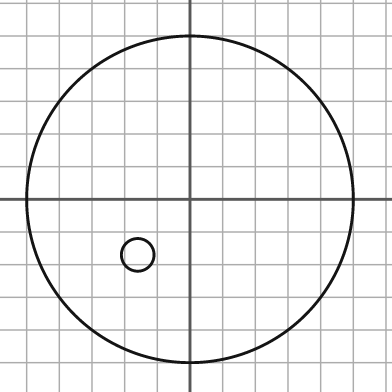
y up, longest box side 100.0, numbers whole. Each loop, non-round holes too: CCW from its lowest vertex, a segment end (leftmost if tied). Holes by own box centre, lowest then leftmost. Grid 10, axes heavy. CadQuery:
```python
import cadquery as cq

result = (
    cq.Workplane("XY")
    .moveTo(0.0, 0.0)
    .circle(50.0)
    .moveTo(-16.0, -17.0)
    .circle(5.0)
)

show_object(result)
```